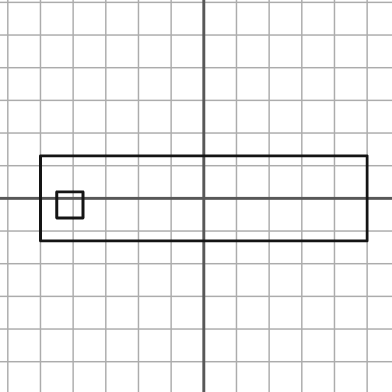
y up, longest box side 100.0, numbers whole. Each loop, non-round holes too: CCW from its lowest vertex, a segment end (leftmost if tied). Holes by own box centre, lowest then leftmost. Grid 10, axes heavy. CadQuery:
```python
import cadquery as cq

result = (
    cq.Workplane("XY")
    .moveTo(-50.0, -13.0)
    .lineTo(50.0, -13.0)
    .lineTo(50.0, 13.0)
    .lineTo(-50.0, 13.0)
    .close()
    .moveTo(-45.0, -6.0)
    .lineTo(-37.0, -6.0)
    .lineTo(-37.0, 2.0)
    .lineTo(-45.0, 2.0)
    .close()
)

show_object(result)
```